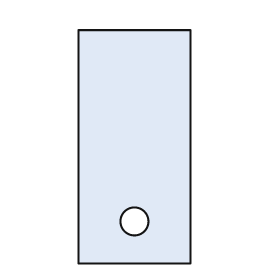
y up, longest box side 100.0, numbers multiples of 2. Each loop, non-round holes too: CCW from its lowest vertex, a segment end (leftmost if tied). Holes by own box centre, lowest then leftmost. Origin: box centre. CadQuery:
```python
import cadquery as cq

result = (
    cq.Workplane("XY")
    .moveTo(-24.0, -50.0)
    .lineTo(24.0, -50.0)
    .lineTo(24.0, 50.0)
    .lineTo(-24.0, 50.0)
    .close()
    .moveTo(0.0, -32.0)
    .circle(6.0)
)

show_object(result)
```